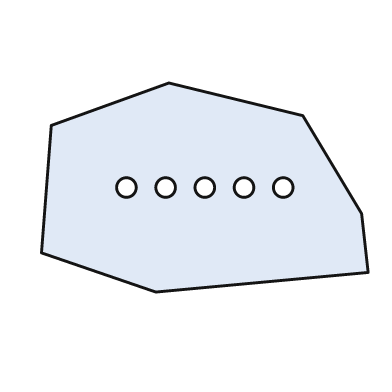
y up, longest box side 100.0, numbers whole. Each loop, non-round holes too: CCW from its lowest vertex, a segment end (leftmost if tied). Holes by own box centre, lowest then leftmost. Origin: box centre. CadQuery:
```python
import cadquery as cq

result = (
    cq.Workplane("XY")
    .moveTo(-15.0, -32.0)
    .lineTo(50.0, -26.0)
    .lineTo(48.0, -8.0)
    .lineTo(30.0, 22.0)
    .lineTo(-11.0, 32.0)
    .lineTo(-47.0, 19.0)
    .lineTo(-50.0, -20.0)
    .close()
    .moveTo(-24.0, 0.0)
    .circle(3.0)
    .moveTo(-12.0, 0.0)
    .circle(3.0)
    .moveTo(0.0, 0.0)
    .circle(3.0)
    .moveTo(12.0, 0.0)
    .circle(3.0)
    .moveTo(24.0, 0.0)
    .circle(3.0)
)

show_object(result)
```